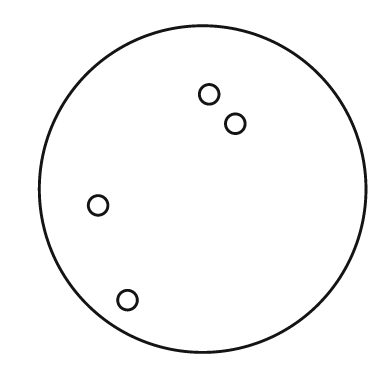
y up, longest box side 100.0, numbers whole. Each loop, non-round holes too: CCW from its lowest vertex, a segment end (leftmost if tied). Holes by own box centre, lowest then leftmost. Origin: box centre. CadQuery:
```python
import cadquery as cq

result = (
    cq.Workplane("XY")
    .moveTo(0.0, 0.0)
    .circle(50.0)
    .moveTo(-23.0, -34.0)
    .circle(3.0)
    .moveTo(-32.0, -5.0)
    .circle(3.0)
    .moveTo(10.0, 20.0)
    .circle(3.0)
    .moveTo(2.0, 29.0)
    .circle(3.0)
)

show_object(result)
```